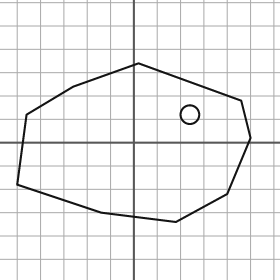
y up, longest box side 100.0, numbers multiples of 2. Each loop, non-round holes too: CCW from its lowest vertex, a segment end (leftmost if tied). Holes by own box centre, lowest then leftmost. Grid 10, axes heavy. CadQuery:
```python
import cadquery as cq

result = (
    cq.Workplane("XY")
    .moveTo(18.0, -34.0)
    .lineTo(40.0, -22.0)
    .lineTo(50.0, 2.0)
    .lineTo(46.0, 18.0)
    .lineTo(2.0, 34.0)
    .lineTo(-26.0, 24.0)
    .lineTo(-46.0, 12.0)
    .lineTo(-50.0, -18.0)
    .lineTo(-14.0, -30.0)
    .close()
    .moveTo(24.0, 12.0)
    .circle(4.0)
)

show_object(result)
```